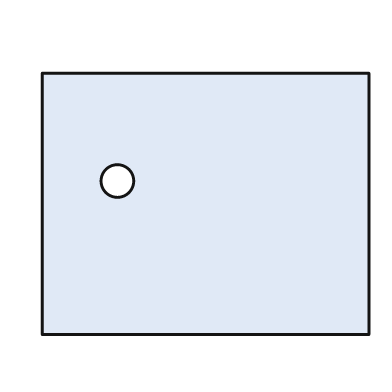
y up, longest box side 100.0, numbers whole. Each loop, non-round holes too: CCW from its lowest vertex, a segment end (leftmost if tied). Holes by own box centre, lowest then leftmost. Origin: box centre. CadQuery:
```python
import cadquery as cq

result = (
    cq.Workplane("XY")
    .moveTo(-50.0, -40.0)
    .lineTo(50.0, -40.0)
    .lineTo(50.0, 40.0)
    .lineTo(-50.0, 40.0)
    .close()
    .moveTo(-27.0, 7.0)
    .circle(5.0)
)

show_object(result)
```